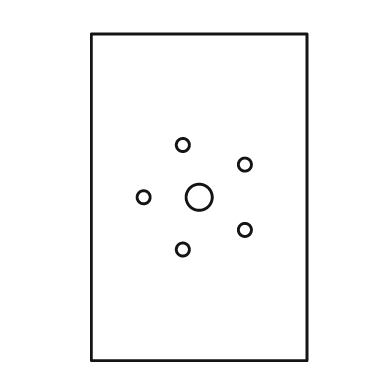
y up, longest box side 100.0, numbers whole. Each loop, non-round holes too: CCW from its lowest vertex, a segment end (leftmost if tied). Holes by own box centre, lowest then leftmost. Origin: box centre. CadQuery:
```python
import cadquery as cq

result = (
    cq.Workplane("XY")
    .moveTo(-33.0, -50.0)
    .lineTo(33.0, -50.0)
    .lineTo(33.0, 50.0)
    .lineTo(-33.0, 50.0)
    .close()
    .moveTo(-5.0, -16.0)
    .circle(2.0)
    .moveTo(14.0, -10.0)
    .circle(2.0)
    .moveTo(-17.0, 0.0)
    .circle(2.0)
    .moveTo(0.0, 0.0)
    .circle(4.0)
    .moveTo(14.0, 10.0)
    .circle(2.0)
    .moveTo(-5.0, 16.0)
    .circle(2.0)
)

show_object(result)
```